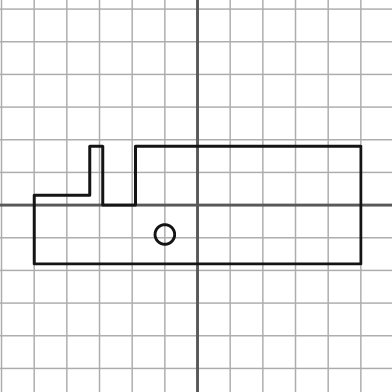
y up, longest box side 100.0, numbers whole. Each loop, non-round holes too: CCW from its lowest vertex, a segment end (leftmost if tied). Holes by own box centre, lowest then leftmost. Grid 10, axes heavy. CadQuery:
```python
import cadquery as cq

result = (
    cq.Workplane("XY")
    .moveTo(-50.0, -18.0)
    .lineTo(50.0, -18.0)
    .lineTo(50.0, 18.0)
    .lineTo(-19.0, 18.0)
    .lineTo(-19.0, 0.0)
    .lineTo(-29.0, 0.0)
    .lineTo(-29.0, 18.0)
    .lineTo(-33.0, 18.0)
    .lineTo(-33.0, 3.0)
    .lineTo(-50.0, 3.0)
    .close()
    .moveTo(-10.0, -9.0)
    .circle(3.0)
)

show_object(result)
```